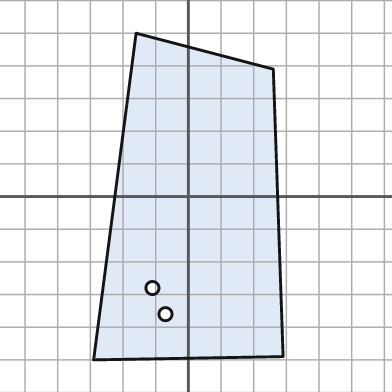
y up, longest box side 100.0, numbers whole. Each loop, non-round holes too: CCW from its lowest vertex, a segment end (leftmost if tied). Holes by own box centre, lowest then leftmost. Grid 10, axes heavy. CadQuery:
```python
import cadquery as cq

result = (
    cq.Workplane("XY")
    .moveTo(-29.0, -50.0)
    .lineTo(29.0, -49.0)
    .lineTo(26.0, 39.0)
    .lineTo(-16.0, 50.0)
    .close()
    .moveTo(-7.0, -36.0)
    .circle(2.0)
    .moveTo(-11.0, -28.0)
    .circle(2.0)
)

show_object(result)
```